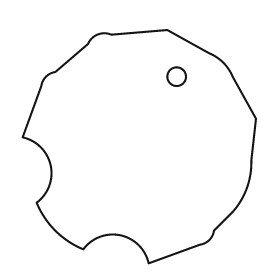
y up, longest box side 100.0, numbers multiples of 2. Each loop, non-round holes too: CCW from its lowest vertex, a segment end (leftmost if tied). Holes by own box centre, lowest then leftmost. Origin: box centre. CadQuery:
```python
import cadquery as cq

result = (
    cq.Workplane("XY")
    .moveTo(4.0, -50.0)
    .lineTo(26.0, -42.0)
    .threePointArc((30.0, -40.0), (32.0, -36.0))
    .lineTo(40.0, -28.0)
    .threePointArc((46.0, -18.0), (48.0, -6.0))
    .lineTo(50.0, 12.0)
    .lineTo(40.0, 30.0)
    .threePointArc((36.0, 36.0), (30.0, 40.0))
    .lineTo(12.0, 50.0)
    .lineTo(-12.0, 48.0)
    .threePointArc((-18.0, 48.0), (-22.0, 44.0))
    .lineTo(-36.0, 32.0)
    .threePointArc((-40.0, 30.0), (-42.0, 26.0))
    .lineTo(-50.0, 4.0)
    .threePointArc((-38.0, -8.0), (-44.0, -24.0))
    .threePointArc((-36.0, -36.0), (-24.0, -44.0))
    .threePointArc((-8.0, -38.0), (4.0, -50.0))
    .close()
    .moveTo(16.0, 30.0)
    .circle(4.0)
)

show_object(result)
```